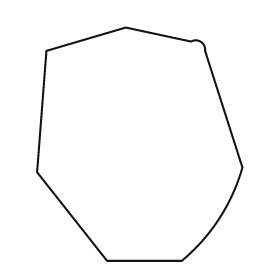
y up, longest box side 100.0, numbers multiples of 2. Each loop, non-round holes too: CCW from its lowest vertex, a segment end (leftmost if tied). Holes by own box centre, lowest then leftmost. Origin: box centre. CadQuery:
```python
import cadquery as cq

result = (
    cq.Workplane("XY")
    .moveTo(-14.0, -50.0)
    .lineTo(18.0, -50.0)
    .threePointArc((34.0, -32.0), (44.0, -10.0))
    .lineTo(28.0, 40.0)
    .threePointArc((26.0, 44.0), (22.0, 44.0))
    .lineTo(-6.0, 50.0)
    .lineTo(-40.0, 40.0)
    .lineTo(-44.0, -12.0)
    .close()
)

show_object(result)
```